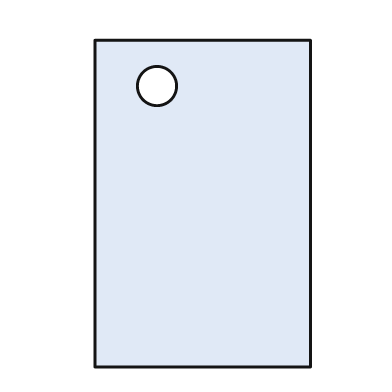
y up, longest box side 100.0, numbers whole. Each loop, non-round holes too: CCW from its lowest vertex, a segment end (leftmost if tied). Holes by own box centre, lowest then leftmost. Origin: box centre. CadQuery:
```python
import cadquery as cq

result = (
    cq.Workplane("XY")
    .moveTo(-33.0, -50.0)
    .lineTo(33.0, -50.0)
    .lineTo(33.0, 50.0)
    .lineTo(-33.0, 50.0)
    .close()
    .moveTo(-14.0, 36.0)
    .circle(6.0)
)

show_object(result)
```